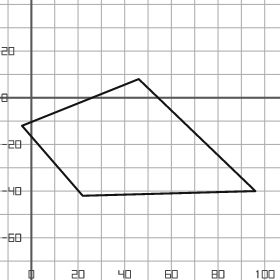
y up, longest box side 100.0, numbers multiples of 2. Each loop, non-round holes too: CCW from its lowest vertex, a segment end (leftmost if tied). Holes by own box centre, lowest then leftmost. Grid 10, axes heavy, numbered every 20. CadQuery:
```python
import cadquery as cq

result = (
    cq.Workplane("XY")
    .moveTo(22.0, -42.0)
    .lineTo(96.0, -40.0)
    .lineTo(46.0, 8.0)
    .lineTo(-4.0, -12.0)
    .close()
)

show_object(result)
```